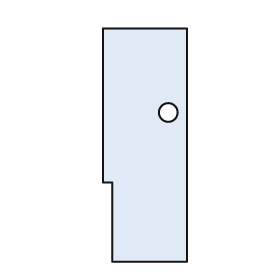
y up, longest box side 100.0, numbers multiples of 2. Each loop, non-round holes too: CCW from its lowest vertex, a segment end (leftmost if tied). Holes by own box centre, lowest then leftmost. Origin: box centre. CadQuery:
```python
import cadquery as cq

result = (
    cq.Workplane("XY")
    .moveTo(-14.0, -50.0)
    .lineTo(18.0, -50.0)
    .lineTo(18.0, 50.0)
    .lineTo(-18.0, 50.0)
    .lineTo(-18.0, -16.0)
    .lineTo(-14.0, -16.0)
    .close()
    .moveTo(10.0, 14.0)
    .circle(4.0)
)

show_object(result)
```